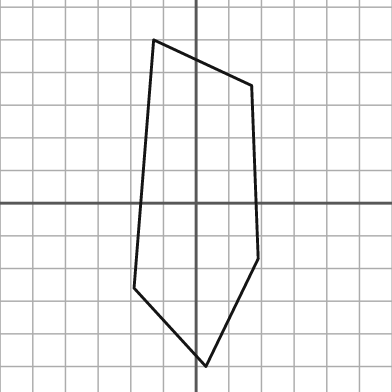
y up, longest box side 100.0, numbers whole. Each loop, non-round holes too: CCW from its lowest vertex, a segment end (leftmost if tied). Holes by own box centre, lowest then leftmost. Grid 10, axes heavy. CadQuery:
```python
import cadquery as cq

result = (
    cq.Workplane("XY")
    .moveTo(3.0, -50.0)
    .lineTo(19.0, -17.0)
    .lineTo(17.0, 36.0)
    .lineTo(-13.0, 50.0)
    .lineTo(-19.0, -26.0)
    .close()
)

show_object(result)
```